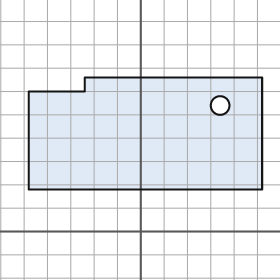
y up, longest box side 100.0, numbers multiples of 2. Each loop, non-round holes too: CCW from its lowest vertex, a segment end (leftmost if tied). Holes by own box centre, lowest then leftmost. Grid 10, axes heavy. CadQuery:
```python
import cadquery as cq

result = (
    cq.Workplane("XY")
    .moveTo(-48.0, 18.0)
    .lineTo(52.0, 18.0)
    .lineTo(52.0, 66.0)
    .lineTo(-24.0, 66.0)
    .lineTo(-24.0, 60.0)
    .lineTo(-48.0, 60.0)
    .close()
    .moveTo(34.0, 54.0)
    .circle(4.0)
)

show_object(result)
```